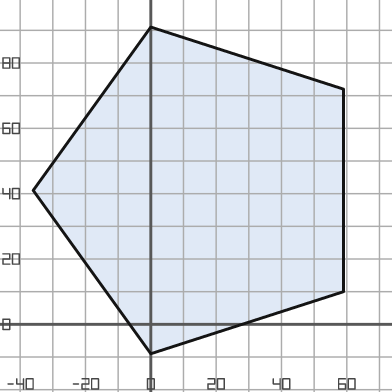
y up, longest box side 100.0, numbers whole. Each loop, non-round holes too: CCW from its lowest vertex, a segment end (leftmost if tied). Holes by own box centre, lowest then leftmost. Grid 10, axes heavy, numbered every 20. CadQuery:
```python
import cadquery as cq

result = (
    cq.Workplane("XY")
    .moveTo(0.0, -9.0)
    .lineTo(59.0, 10.0)
    .lineTo(59.0, 72.0)
    .lineTo(0.0, 91.0)
    .lineTo(-36.0, 41.0)
    .close()
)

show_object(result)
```